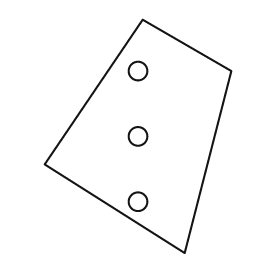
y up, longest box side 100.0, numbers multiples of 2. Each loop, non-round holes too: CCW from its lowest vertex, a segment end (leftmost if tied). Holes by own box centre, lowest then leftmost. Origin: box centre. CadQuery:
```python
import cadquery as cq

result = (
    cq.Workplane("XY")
    .moveTo(20.0, -50.0)
    .lineTo(40.0, 28.0)
    .lineTo(2.0, 50.0)
    .lineTo(-40.0, -12.0)
    .close()
    .moveTo(0.0, -28.0)
    .circle(4.0)
    .moveTo(0.0, 0.0)
    .circle(4.0)
    .moveTo(0.0, 28.0)
    .circle(4.0)
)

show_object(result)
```